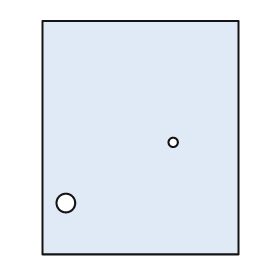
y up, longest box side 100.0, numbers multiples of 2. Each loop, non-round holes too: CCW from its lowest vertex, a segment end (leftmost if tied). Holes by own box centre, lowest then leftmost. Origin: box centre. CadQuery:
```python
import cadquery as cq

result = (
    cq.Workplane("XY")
    .moveTo(-42.0, -50.0)
    .lineTo(42.0, -50.0)
    .lineTo(42.0, 50.0)
    .lineTo(-42.0, 50.0)
    .close()
    .moveTo(-32.0, -28.0)
    .circle(4.0)
    .moveTo(14.0, -2.0)
    .circle(2.0)
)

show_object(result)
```